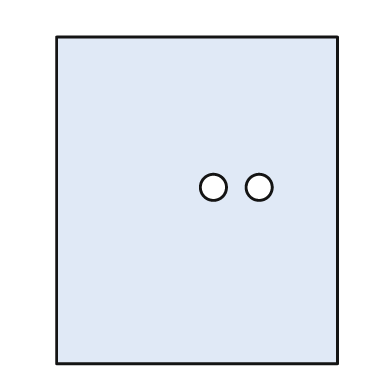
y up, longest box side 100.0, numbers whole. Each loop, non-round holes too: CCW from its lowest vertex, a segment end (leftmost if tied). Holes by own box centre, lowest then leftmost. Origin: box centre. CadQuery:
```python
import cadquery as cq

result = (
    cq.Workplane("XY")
    .moveTo(-43.0, -50.0)
    .lineTo(43.0, -50.0)
    .lineTo(43.0, 50.0)
    .lineTo(-43.0, 50.0)
    .close()
    .moveTo(5.0, 4.0)
    .circle(4.0)
    .moveTo(19.0, 4.0)
    .circle(4.0)
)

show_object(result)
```